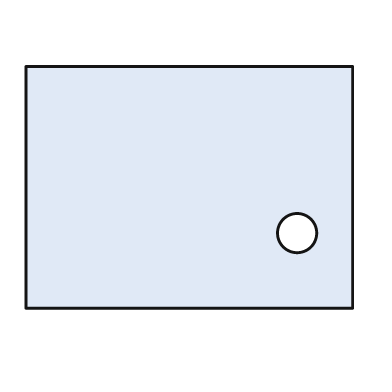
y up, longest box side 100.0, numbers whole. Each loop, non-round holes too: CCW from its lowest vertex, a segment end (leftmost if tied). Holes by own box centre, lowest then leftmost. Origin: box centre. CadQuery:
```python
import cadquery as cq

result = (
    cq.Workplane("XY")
    .moveTo(-50.0, -37.0)
    .lineTo(50.0, -37.0)
    .lineTo(50.0, 37.0)
    .lineTo(-50.0, 37.0)
    .close()
    .moveTo(33.0, -14.0)
    .circle(6.0)
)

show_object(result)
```